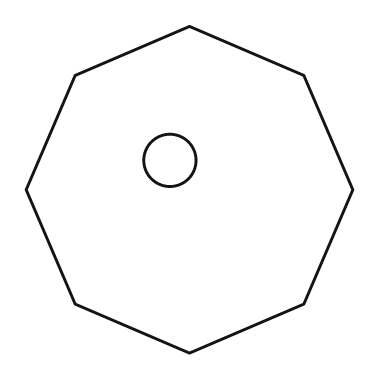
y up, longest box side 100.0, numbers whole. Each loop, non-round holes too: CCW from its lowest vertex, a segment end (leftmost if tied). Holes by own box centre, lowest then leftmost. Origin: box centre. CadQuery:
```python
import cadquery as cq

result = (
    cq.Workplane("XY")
    .moveTo(0.0, -50.0)
    .lineTo(35.0, -35.0)
    .lineTo(50.0, 0.0)
    .lineTo(35.0, 35.0)
    .lineTo(0.0, 50.0)
    .lineTo(-35.0, 35.0)
    .lineTo(-50.0, 0.0)
    .lineTo(-35.0, -35.0)
    .close()
    .moveTo(-6.0, 9.0)
    .circle(8.0)
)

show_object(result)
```